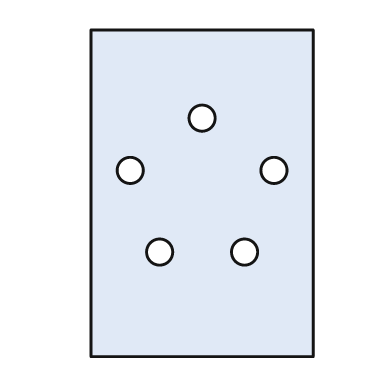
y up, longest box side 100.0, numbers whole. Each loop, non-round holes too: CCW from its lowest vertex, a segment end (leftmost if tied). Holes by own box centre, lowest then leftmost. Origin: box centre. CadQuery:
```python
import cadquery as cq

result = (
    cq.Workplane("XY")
    .moveTo(-34.0, -50.0)
    .lineTo(34.0, -50.0)
    .lineTo(34.0, 50.0)
    .lineTo(-34.0, 50.0)
    .close()
    .moveTo(-13.0, -18.0)
    .circle(4.0)
    .moveTo(13.0, -18.0)
    .circle(4.0)
    .moveTo(-22.0, 7.0)
    .circle(4.0)
    .moveTo(22.0, 7.0)
    .circle(4.0)
    .moveTo(0.0, 23.0)
    .circle(4.0)
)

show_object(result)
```